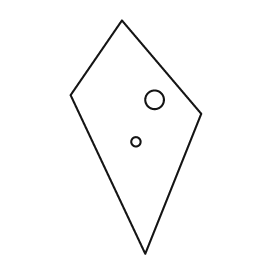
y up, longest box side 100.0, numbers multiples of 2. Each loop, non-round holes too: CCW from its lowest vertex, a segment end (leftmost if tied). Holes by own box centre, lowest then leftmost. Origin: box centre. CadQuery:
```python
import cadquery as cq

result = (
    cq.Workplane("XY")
    .moveTo(4.0, -50.0)
    .lineTo(28.0, 10.0)
    .lineTo(-6.0, 50.0)
    .lineTo(-28.0, 18.0)
    .close()
    .moveTo(0.0, -2.0)
    .circle(2.0)
    .moveTo(8.0, 16.0)
    .circle(4.0)
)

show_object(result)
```